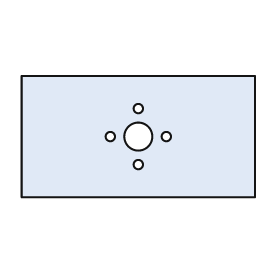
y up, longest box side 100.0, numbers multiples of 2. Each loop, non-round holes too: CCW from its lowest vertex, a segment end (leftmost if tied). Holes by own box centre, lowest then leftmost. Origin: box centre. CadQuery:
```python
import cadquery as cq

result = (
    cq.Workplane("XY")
    .moveTo(-50.0, -26.0)
    .lineTo(50.0, -26.0)
    .lineTo(50.0, 26.0)
    .lineTo(-50.0, 26.0)
    .close()
    .moveTo(0.0, -12.0)
    .circle(2.0)
    .moveTo(-12.0, 0.0)
    .circle(2.0)
    .moveTo(0.0, 0.0)
    .circle(6.0)
    .moveTo(12.0, 0.0)
    .circle(2.0)
    .moveTo(0.0, 12.0)
    .circle(2.0)
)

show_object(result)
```